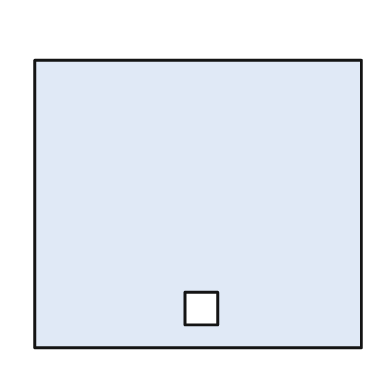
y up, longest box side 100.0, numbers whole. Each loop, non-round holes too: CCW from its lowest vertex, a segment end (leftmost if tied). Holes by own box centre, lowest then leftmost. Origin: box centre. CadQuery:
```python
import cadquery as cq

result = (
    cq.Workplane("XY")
    .moveTo(-50.0, -44.0)
    .lineTo(50.0, -44.0)
    .lineTo(50.0, 44.0)
    .lineTo(-50.0, 44.0)
    .close()
    .moveTo(-4.0, -37.0)
    .lineTo(6.0, -37.0)
    .lineTo(6.0, -27.0)
    .lineTo(-4.0, -27.0)
    .close()
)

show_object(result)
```